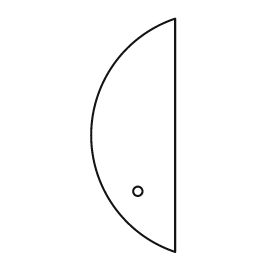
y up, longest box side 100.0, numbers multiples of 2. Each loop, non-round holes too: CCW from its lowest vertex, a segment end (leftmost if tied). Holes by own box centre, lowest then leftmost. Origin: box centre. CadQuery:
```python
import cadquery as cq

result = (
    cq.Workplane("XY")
    .moveTo(18.0, -50.0)
    .lineTo(18.0, 50.0)
    .threePointArc((-18.0, 0.0), (18.0, -50.0))
    .close()
    .moveTo(2.0, -24.0)
    .circle(2.0)
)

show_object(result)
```